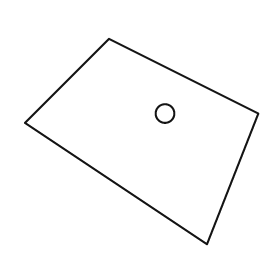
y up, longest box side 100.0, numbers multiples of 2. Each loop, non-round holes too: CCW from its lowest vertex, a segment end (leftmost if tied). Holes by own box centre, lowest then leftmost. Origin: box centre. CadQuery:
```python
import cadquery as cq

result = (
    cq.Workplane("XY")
    .moveTo(28.0, -44.0)
    .lineTo(50.0, 12.0)
    .lineTo(-14.0, 44.0)
    .lineTo(-50.0, 8.0)
    .close()
    .moveTo(10.0, 12.0)
    .circle(4.0)
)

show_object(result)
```